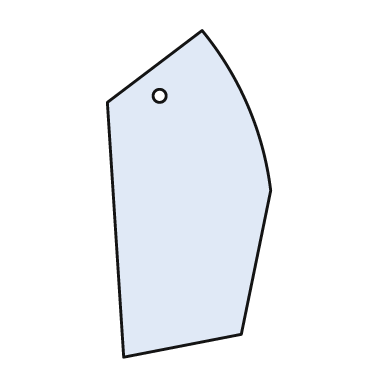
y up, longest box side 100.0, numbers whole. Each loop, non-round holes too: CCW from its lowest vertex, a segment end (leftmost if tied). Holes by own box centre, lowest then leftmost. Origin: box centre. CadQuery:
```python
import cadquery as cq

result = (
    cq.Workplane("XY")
    .moveTo(-20.0, -50.0)
    .lineTo(16.0, -43.0)
    .lineTo(25.0, 1.0)
    .threePointArc((18.0, 27.0), (4.0, 50.0))
    .lineTo(-25.0, 28.0)
    .close()
    .moveTo(-9.0, 30.0)
    .circle(2.0)
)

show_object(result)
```